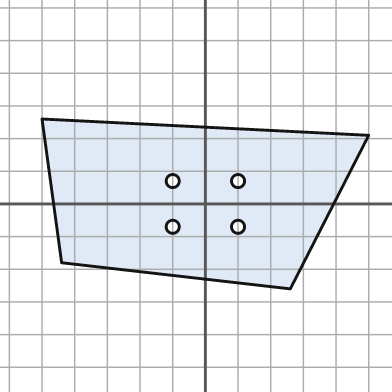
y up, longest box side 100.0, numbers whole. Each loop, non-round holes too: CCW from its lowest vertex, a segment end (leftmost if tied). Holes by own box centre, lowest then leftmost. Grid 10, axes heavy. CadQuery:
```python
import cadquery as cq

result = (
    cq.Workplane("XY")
    .moveTo(26.0, -26.0)
    .lineTo(50.0, 21.0)
    .lineTo(-50.0, 26.0)
    .lineTo(-44.0, -18.0)
    .close()
    .moveTo(-10.0, -7.0)
    .circle(2.0)
    .moveTo(10.0, -7.0)
    .circle(2.0)
    .moveTo(-10.0, 7.0)
    .circle(2.0)
    .moveTo(10.0, 7.0)
    .circle(2.0)
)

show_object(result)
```